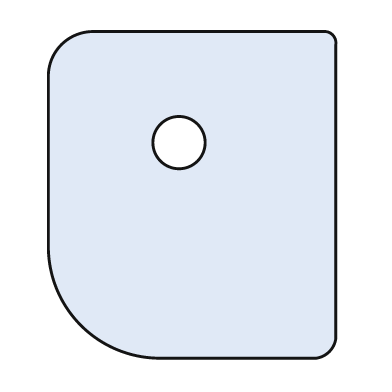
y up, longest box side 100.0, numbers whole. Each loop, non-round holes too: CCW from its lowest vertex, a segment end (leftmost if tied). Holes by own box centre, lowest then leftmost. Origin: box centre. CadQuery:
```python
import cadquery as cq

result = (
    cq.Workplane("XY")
    .moveTo(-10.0, -50.0)
    .lineTo(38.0, -50.0)
    .threePointArc((42.0, -48.0), (44.0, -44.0))
    .lineTo(44.0, 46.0)
    .threePointArc((43.0, 49.0), (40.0, 50.0))
    .lineTo(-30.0, 50.0)
    .threePointArc((-40.0, 46.0), (-44.0, 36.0))
    .lineTo(-44.0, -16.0)
    .threePointArc((-34.0, -40.0), (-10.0, -50.0))
    .close()
    .moveTo(-4.0, 16.0)
    .circle(8.0)
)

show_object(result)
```